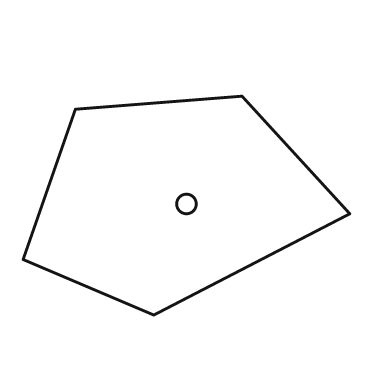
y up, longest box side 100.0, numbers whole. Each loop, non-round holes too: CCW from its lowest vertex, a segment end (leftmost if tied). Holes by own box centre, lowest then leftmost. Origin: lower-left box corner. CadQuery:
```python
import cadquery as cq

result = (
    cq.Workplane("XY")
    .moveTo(40.0, 0.0)
    .lineTo(100.0, 31.0)
    .lineTo(67.0, 67.0)
    .lineTo(16.0, 63.0)
    .lineTo(0.0, 17.0)
    .close()
    .moveTo(50.0, 34.0)
    .circle(3.0)
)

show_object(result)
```